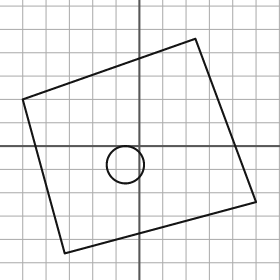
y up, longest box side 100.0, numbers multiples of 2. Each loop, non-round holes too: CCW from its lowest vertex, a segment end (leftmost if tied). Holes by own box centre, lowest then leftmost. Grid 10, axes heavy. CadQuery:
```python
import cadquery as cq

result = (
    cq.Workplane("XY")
    .moveTo(-32.0, -46.0)
    .lineTo(50.0, -24.0)
    .lineTo(24.0, 46.0)
    .lineTo(-50.0, 20.0)
    .close()
    .moveTo(-6.0, -8.0)
    .circle(8.0)
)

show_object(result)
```